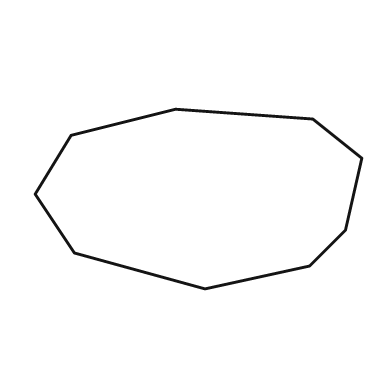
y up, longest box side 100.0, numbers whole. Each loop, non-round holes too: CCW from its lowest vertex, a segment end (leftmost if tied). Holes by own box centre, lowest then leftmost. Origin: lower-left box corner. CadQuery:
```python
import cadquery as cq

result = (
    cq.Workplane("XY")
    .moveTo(52.0, 0.0)
    .lineTo(84.0, 7.0)
    .lineTo(95.0, 18.0)
    .lineTo(100.0, 40.0)
    .lineTo(85.0, 52.0)
    .lineTo(43.0, 55.0)
    .lineTo(11.0, 47.0)
    .lineTo(0.0, 29.0)
    .lineTo(12.0, 11.0)
    .close()
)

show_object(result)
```